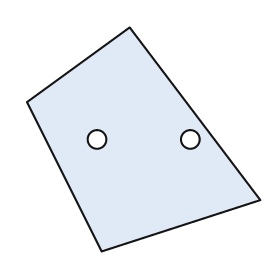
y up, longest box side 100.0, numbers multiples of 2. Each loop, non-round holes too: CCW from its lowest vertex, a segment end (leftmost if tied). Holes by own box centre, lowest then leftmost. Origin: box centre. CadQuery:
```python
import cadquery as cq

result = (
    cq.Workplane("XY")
    .moveTo(-18.0, -48.0)
    .lineTo(50.0, -26.0)
    .lineTo(-6.0, 48.0)
    .lineTo(-50.0, 16.0)
    .close()
    .moveTo(-20.0, 0.0)
    .circle(4.0)
    .moveTo(20.0, 0.0)
    .circle(4.0)
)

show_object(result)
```